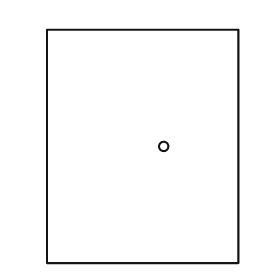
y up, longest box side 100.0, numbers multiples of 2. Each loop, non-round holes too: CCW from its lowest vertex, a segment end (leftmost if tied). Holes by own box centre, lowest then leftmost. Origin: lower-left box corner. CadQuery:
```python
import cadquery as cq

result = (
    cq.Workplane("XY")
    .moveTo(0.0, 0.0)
    .lineTo(82.0, 0.0)
    .lineTo(82.0, 100.0)
    .lineTo(0.0, 100.0)
    .close()
    .moveTo(50.0, 50.0)
    .circle(2.0)
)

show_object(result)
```